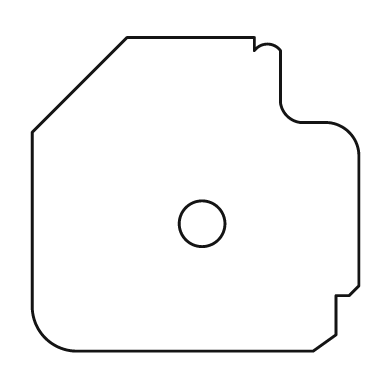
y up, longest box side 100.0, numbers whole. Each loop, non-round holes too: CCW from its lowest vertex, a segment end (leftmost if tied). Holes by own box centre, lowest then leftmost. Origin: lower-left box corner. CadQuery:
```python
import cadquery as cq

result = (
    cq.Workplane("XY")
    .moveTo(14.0, 0.0)
    .lineTo(86.0, 0.0)
    .lineTo(93.0, 5.0)
    .lineTo(93.0, 17.0)
    .lineTo(97.0, 17.0)
    .lineTo(100.0, 20.0)
    .lineTo(100.0, 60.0)
    .threePointArc((97.0, 67.0), (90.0, 70.0))
    .lineTo(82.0, 70.0)
    .threePointArc((78.0, 72.0), (76.0, 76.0))
    .lineTo(76.0, 92.0)
    .threePointArc((72.0, 94.0), (68.0, 92.0))
    .lineTo(68.0, 96.0)
    .lineTo(29.0, 96.0)
    .lineTo(0.0, 67.0)
    .lineTo(0.0, 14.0)
    .threePointArc((4.0, 4.0), (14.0, 0.0))
    .close()
    .moveTo(52.0, 39.0)
    .circle(7.0)
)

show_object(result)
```